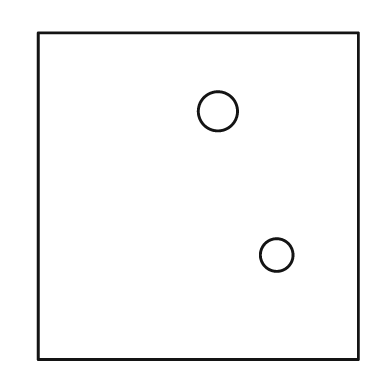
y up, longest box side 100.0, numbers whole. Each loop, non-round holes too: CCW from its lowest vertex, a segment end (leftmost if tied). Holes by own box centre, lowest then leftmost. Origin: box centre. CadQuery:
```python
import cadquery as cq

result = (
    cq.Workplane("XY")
    .moveTo(-49.0, -50.0)
    .lineTo(49.0, -50.0)
    .lineTo(49.0, 50.0)
    .lineTo(-49.0, 50.0)
    .close()
    .moveTo(24.0, -18.0)
    .circle(5.0)
    .moveTo(6.0, 26.0)
    .circle(6.0)
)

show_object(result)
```